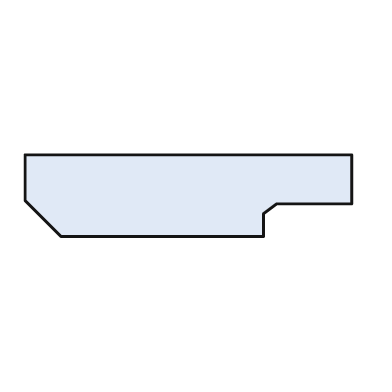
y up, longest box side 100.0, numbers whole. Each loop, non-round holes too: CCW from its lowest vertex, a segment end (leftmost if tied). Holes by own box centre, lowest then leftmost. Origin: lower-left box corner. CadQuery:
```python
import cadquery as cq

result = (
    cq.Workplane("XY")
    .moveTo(11.0, 0.0)
    .lineTo(73.0, 0.0)
    .lineTo(73.0, 7.0)
    .lineTo(77.0, 10.0)
    .lineTo(100.0, 10.0)
    .lineTo(100.0, 25.0)
    .lineTo(0.0, 25.0)
    .lineTo(0.0, 11.0)
    .close()
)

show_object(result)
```